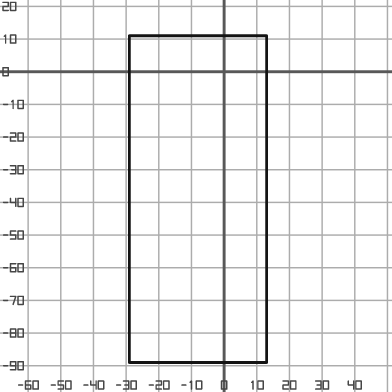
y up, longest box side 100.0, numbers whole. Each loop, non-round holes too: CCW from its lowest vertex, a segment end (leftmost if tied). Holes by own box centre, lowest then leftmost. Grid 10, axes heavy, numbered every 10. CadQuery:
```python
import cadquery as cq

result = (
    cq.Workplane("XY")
    .moveTo(-29.0, -89.0)
    .lineTo(13.0, -89.0)
    .lineTo(13.0, 11.0)
    .lineTo(-29.0, 11.0)
    .close()
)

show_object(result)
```